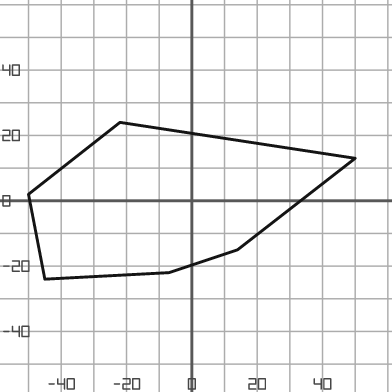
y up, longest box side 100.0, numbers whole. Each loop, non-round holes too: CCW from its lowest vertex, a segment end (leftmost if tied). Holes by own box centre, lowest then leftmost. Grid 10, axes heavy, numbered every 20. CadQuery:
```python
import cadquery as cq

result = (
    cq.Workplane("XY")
    .moveTo(-45.0, -24.0)
    .lineTo(-7.0, -22.0)
    .lineTo(14.0, -15.0)
    .lineTo(50.0, 13.0)
    .lineTo(-22.0, 24.0)
    .lineTo(-50.0, 2.0)
    .close()
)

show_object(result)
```